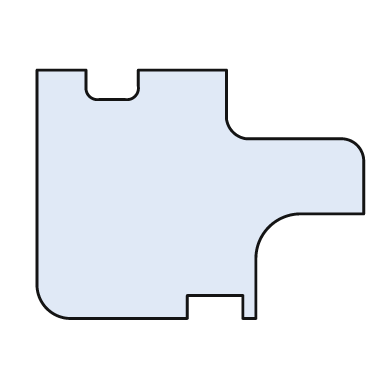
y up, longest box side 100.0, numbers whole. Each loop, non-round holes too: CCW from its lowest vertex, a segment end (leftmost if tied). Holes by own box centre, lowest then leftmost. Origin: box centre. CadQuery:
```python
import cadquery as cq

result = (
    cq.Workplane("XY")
    .moveTo(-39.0, -38.0)
    .lineTo(-4.0, -38.0)
    .lineTo(-4.0, -31.0)
    .lineTo(13.0, -31.0)
    .lineTo(13.0, -38.0)
    .lineTo(17.0, -38.0)
    .lineTo(17.0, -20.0)
    .threePointArc((21.0, -10.0), (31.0, -6.0))
    .lineTo(50.0, -6.0)
    .lineTo(50.0, 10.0)
    .threePointArc((48.0, 15.0), (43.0, 17.0))
    .lineTo(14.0, 17.0)
    .threePointArc((10.0, 19.0), (8.0, 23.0))
    .lineTo(8.0, 38.0)
    .lineTo(-19.0, 38.0)
    .lineTo(-19.0, 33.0)
    .threePointArc((-20.0, 30.0), (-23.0, 29.0))
    .lineTo(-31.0, 29.0)
    .threePointArc((-34.0, 30.0), (-35.0, 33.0))
    .lineTo(-35.0, 38.0)
    .lineTo(-50.0, 38.0)
    .lineTo(-50.0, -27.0)
    .threePointArc((-47.0, -35.0), (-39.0, -38.0))
    .close()
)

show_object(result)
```